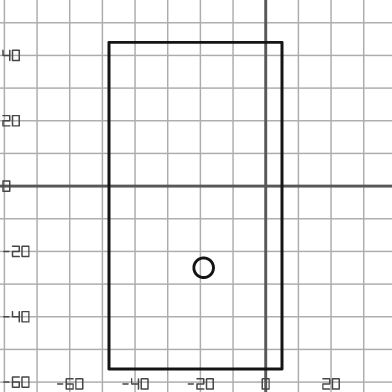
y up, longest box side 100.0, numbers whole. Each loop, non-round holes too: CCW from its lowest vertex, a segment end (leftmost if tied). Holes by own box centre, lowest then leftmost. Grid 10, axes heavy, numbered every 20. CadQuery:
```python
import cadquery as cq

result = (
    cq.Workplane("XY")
    .moveTo(-48.0, -56.0)
    .lineTo(5.0, -56.0)
    .lineTo(5.0, 44.0)
    .lineTo(-48.0, 44.0)
    .close()
    .moveTo(-19.0, -25.0)
    .circle(3.0)
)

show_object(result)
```